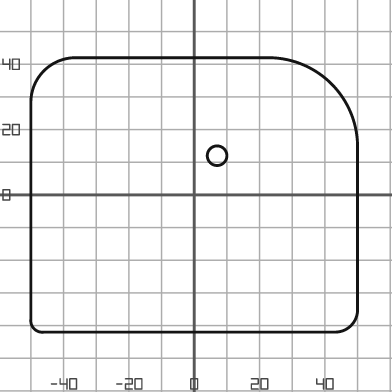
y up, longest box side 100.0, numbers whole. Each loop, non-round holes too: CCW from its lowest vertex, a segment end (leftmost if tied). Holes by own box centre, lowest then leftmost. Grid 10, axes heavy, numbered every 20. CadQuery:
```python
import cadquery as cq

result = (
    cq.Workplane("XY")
    .moveTo(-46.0, -42.0)
    .lineTo(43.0, -42.0)
    .threePointArc((48.0, -40.0), (50.0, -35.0))
    .lineTo(50.0, 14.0)
    .threePointArc((42.0, 34.0), (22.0, 42.0))
    .lineTo(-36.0, 42.0)
    .threePointArc((-46.0, 38.0), (-50.0, 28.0))
    .lineTo(-50.0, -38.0)
    .threePointArc((-49.0, -41.0), (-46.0, -42.0))
    .close()
    .moveTo(7.0, 12.0)
    .circle(3.0)
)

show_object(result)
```